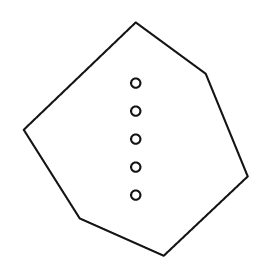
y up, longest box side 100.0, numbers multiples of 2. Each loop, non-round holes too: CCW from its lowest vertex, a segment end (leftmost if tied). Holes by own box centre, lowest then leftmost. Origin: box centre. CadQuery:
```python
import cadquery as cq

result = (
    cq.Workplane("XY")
    .moveTo(12.0, -50.0)
    .lineTo(48.0, -16.0)
    .lineTo(30.0, 28.0)
    .lineTo(0.0, 50.0)
    .lineTo(-48.0, 4.0)
    .lineTo(-24.0, -34.0)
    .close()
    .moveTo(0.0, -24.0)
    .circle(2.0)
    .moveTo(0.0, -12.0)
    .circle(2.0)
    .moveTo(0.0, 0.0)
    .circle(2.0)
    .moveTo(0.0, 12.0)
    .circle(2.0)
    .moveTo(0.0, 24.0)
    .circle(2.0)
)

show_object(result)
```